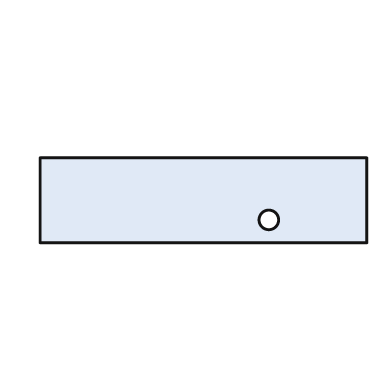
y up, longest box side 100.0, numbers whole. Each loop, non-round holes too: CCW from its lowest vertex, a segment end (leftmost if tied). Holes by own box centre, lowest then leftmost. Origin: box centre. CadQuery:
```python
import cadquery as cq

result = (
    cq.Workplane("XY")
    .moveTo(-50.0, -13.0)
    .lineTo(50.0, -13.0)
    .lineTo(50.0, 13.0)
    .lineTo(-50.0, 13.0)
    .close()
    .moveTo(20.0, -6.0)
    .circle(3.0)
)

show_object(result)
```